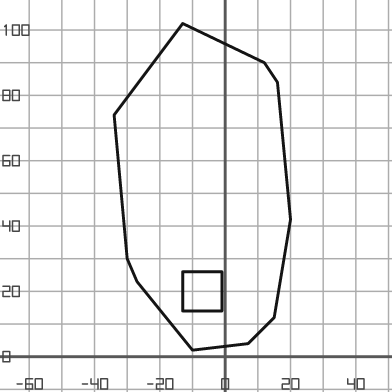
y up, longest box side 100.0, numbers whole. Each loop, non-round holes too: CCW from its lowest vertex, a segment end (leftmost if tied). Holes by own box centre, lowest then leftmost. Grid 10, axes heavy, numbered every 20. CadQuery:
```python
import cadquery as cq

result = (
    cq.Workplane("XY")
    .moveTo(-10.0, 2.0)
    .lineTo(7.0, 4.0)
    .lineTo(15.0, 12.0)
    .lineTo(20.0, 42.0)
    .lineTo(16.0, 84.0)
    .lineTo(12.0, 90.0)
    .lineTo(-13.0, 102.0)
    .lineTo(-34.0, 74.0)
    .lineTo(-30.0, 30.0)
    .lineTo(-27.0, 23.0)
    .close()
    .moveTo(-13.0, 14.0)
    .lineTo(-1.0, 14.0)
    .lineTo(-1.0, 26.0)
    .lineTo(-13.0, 26.0)
    .close()
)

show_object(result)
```